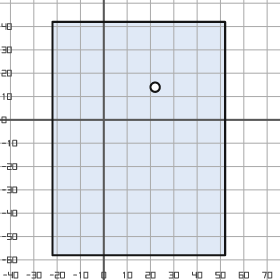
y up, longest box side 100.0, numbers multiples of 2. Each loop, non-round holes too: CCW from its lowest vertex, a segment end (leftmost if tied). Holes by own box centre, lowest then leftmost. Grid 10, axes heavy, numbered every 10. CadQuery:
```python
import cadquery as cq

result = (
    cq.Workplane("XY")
    .moveTo(-22.0, -58.0)
    .lineTo(52.0, -58.0)
    .lineTo(52.0, 42.0)
    .lineTo(-22.0, 42.0)
    .close()
    .moveTo(22.0, 14.0)
    .circle(2.0)
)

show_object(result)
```